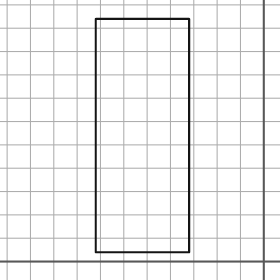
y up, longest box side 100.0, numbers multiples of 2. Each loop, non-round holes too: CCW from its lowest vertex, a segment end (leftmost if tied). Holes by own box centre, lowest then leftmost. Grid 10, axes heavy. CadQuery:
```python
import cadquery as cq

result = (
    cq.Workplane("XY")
    .moveTo(-72.0, 4.0)
    .lineTo(-32.0, 4.0)
    .lineTo(-32.0, 104.0)
    .lineTo(-72.0, 104.0)
    .close()
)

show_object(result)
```